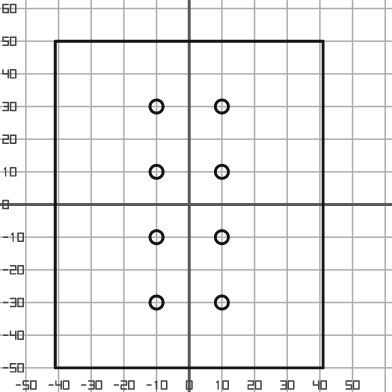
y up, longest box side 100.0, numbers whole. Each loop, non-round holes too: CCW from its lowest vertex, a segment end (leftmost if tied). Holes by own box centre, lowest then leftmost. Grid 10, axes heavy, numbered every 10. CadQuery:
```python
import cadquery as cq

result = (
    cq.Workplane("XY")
    .moveTo(-41.0, -50.0)
    .lineTo(41.0, -50.0)
    .lineTo(41.0, 50.0)
    .lineTo(-41.0, 50.0)
    .close()
    .moveTo(-10.0, -30.0)
    .circle(2.0)
    .moveTo(10.0, -30.0)
    .circle(2.0)
    .moveTo(-10.0, -10.0)
    .circle(2.0)
    .moveTo(10.0, -10.0)
    .circle(2.0)
    .moveTo(-10.0, 10.0)
    .circle(2.0)
    .moveTo(10.0, 10.0)
    .circle(2.0)
    .moveTo(-10.0, 30.0)
    .circle(2.0)
    .moveTo(10.0, 30.0)
    .circle(2.0)
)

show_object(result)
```